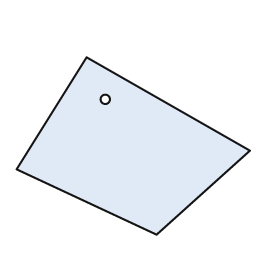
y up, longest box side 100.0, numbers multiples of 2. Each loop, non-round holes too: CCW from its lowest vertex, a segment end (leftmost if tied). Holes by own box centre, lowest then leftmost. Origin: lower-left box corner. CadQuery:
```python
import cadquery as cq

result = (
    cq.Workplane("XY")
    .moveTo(60.0, 0.0)
    .lineTo(100.0, 36.0)
    .lineTo(30.0, 76.0)
    .lineTo(0.0, 28.0)
    .close()
    .moveTo(38.0, 58.0)
    .circle(2.0)
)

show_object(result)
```